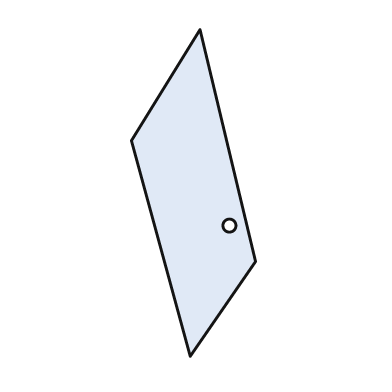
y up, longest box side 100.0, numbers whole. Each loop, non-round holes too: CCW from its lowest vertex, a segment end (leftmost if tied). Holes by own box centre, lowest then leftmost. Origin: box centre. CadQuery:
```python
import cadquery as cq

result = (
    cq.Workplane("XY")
    .moveTo(-1.0, -50.0)
    .lineTo(19.0, -21.0)
    .lineTo(2.0, 50.0)
    .lineTo(-19.0, 16.0)
    .close()
    .moveTo(11.0, -10.0)
    .circle(2.0)
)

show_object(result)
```